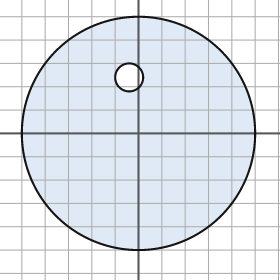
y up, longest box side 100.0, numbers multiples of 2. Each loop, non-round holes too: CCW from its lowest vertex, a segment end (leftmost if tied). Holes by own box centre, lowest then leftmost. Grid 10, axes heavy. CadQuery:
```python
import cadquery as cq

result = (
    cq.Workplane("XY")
    .moveTo(0.0, 0.0)
    .circle(50.0)
    .moveTo(-4.0, 24.0)
    .circle(6.0)
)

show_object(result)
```